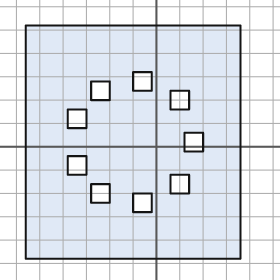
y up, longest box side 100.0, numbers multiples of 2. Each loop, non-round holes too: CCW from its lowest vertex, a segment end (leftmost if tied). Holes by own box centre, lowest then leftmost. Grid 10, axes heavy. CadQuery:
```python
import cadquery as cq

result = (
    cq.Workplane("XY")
    .moveTo(-56.0, -48.0)
    .lineTo(36.0, -48.0)
    .lineTo(36.0, 52.0)
    .lineTo(-56.0, 52.0)
    .close()
    .moveTo(-10.0, -28.0)
    .lineTo(-2.0, -28.0)
    .lineTo(-2.0, -20.0)
    .lineTo(-10.0, -20.0)
    .close()
    .moveTo(-28.0, -24.0)
    .lineTo(-20.0, -24.0)
    .lineTo(-20.0, -16.0)
    .lineTo(-28.0, -16.0)
    .close()
    .moveTo(6.0, -20.0)
    .lineTo(14.0, -20.0)
    .lineTo(14.0, -12.0)
    .lineTo(6.0, -12.0)
    .close()
    .moveTo(-38.0, -12.0)
    .lineTo(-30.0, -12.0)
    .lineTo(-30.0, -4.0)
    .lineTo(-38.0, -4.0)
    .close()
    .moveTo(12.0, -2.0)
    .lineTo(20.0, -2.0)
    .lineTo(20.0, 6.0)
    .lineTo(12.0, 6.0)
    .close()
    .moveTo(-38.0, 8.0)
    .lineTo(-30.0, 8.0)
    .lineTo(-30.0, 16.0)
    .lineTo(-38.0, 16.0)
    .close()
    .moveTo(6.0, 16.0)
    .lineTo(14.0, 16.0)
    .lineTo(14.0, 24.0)
    .lineTo(6.0, 24.0)
    .close()
    .moveTo(-28.0, 20.0)
    .lineTo(-20.0, 20.0)
    .lineTo(-20.0, 28.0)
    .lineTo(-28.0, 28.0)
    .close()
    .moveTo(-10.0, 24.0)
    .lineTo(-2.0, 24.0)
    .lineTo(-2.0, 32.0)
    .lineTo(-10.0, 32.0)
    .close()
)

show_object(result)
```